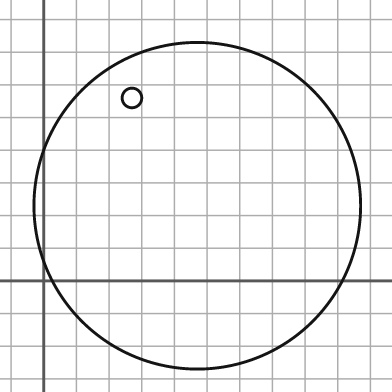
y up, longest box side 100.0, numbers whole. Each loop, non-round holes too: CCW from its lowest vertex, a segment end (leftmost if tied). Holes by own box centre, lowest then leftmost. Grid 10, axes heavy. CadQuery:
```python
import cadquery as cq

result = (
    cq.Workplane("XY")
    .moveTo(47.0, 23.0)
    .circle(50.0)
    .moveTo(27.0, 56.0)
    .circle(3.0)
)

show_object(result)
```